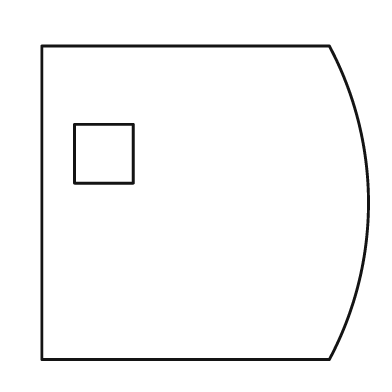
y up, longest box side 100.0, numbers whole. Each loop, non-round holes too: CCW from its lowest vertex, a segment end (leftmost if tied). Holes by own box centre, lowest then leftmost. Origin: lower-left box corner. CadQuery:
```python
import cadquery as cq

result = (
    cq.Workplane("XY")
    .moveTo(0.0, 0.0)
    .lineTo(88.0, 0.0)
    .threePointArc((100.0, 48.0), (88.0, 96.0))
    .lineTo(0.0, 96.0)
    .close()
    .moveTo(10.0, 54.0)
    .lineTo(28.0, 54.0)
    .lineTo(28.0, 72.0)
    .lineTo(10.0, 72.0)
    .close()
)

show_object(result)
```